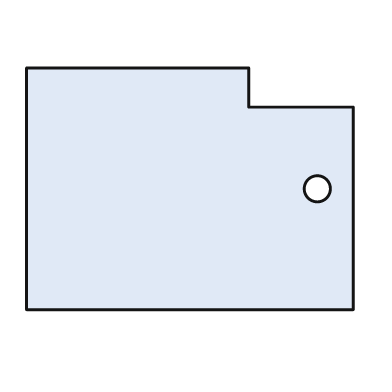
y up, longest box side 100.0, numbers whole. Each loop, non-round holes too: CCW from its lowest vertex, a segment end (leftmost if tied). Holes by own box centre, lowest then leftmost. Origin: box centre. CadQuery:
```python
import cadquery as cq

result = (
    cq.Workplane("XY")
    .moveTo(-50.0, -37.0)
    .lineTo(50.0, -37.0)
    .lineTo(50.0, 25.0)
    .lineTo(18.0, 25.0)
    .lineTo(18.0, 37.0)
    .lineTo(-50.0, 37.0)
    .close()
    .moveTo(39.0, 0.0)
    .circle(4.0)
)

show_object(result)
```